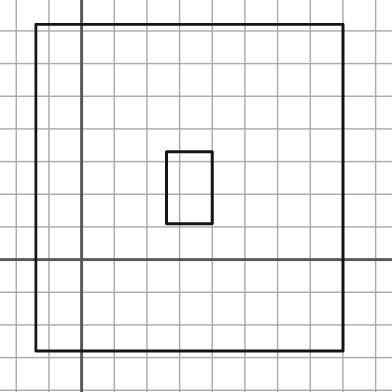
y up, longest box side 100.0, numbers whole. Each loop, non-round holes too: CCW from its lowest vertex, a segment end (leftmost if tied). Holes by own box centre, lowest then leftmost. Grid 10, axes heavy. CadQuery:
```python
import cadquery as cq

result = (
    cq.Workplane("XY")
    .moveTo(-14.0, -28.0)
    .lineTo(80.0, -28.0)
    .lineTo(80.0, 72.0)
    .lineTo(-14.0, 72.0)
    .close()
    .moveTo(26.0, 11.0)
    .lineTo(40.0, 11.0)
    .lineTo(40.0, 33.0)
    .lineTo(26.0, 33.0)
    .close()
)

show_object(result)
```